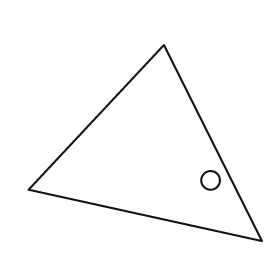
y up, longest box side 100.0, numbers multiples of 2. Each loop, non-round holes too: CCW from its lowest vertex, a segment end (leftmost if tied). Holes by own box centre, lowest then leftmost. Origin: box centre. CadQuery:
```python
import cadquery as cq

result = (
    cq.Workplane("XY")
    .moveTo(50.0, -42.0)
    .lineTo(8.0, 42.0)
    .lineTo(-50.0, -20.0)
    .close()
    .moveTo(28.0, -16.0)
    .circle(4.0)
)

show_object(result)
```